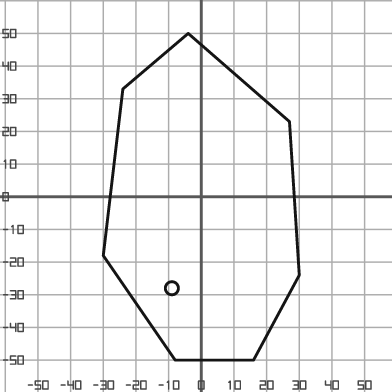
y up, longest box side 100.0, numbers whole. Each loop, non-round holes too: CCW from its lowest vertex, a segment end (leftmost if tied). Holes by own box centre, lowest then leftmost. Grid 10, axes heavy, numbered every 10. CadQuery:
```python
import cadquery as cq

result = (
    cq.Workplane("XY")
    .moveTo(-8.0, -50.0)
    .lineTo(16.0, -50.0)
    .lineTo(30.0, -24.0)
    .lineTo(27.0, 23.0)
    .lineTo(-4.0, 50.0)
    .lineTo(-24.0, 33.0)
    .lineTo(-30.0, -18.0)
    .close()
    .moveTo(-9.0, -28.0)
    .circle(2.0)
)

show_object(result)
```